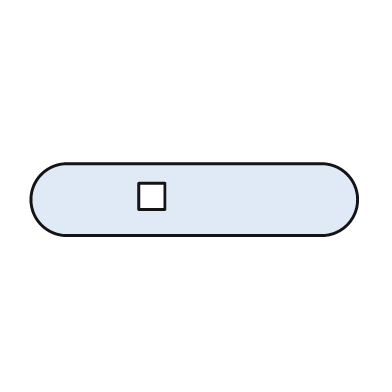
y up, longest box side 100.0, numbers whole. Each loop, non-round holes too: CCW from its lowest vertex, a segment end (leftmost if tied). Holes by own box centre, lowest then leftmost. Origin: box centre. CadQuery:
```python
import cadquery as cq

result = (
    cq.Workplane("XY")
    .moveTo(-39.0, -11.0)
    .lineTo(39.0, -11.0)
    .threePointArc((50.0, 0.0), (39.0, 11.0))
    .lineTo(-39.0, 11.0)
    .threePointArc((-50.0, 0.0), (-39.0, -11.0))
    .close()
    .moveTo(-17.0, -3.0)
    .lineTo(-9.0, -3.0)
    .lineTo(-9.0, 5.0)
    .lineTo(-17.0, 5.0)
    .close()
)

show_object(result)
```